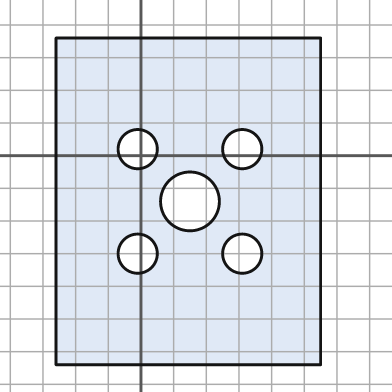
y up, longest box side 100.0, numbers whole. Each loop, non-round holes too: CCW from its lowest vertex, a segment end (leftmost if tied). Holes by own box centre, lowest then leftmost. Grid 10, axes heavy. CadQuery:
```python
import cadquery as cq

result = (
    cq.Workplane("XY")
    .moveTo(-26.0, -64.0)
    .lineTo(55.0, -64.0)
    .lineTo(55.0, 36.0)
    .lineTo(-26.0, 36.0)
    .close()
    .moveTo(-1.0, -30.0)
    .circle(6.0)
    .moveTo(31.0, -30.0)
    .circle(6.0)
    .moveTo(15.0, -14.0)
    .circle(9.0)
    .moveTo(-1.0, 2.0)
    .circle(6.0)
    .moveTo(31.0, 2.0)
    .circle(6.0)
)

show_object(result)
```